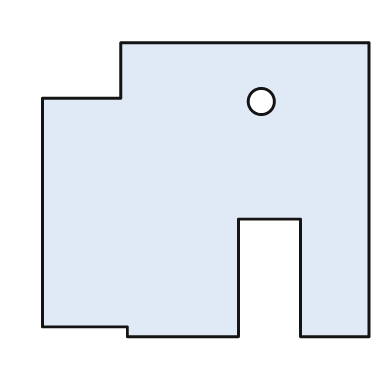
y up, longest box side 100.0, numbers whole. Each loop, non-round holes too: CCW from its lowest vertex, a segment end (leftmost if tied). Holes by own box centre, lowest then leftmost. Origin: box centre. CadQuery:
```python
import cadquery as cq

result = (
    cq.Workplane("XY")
    .moveTo(-24.0, -45.0)
    .lineTo(10.0, -45.0)
    .lineTo(10.0, -9.0)
    .lineTo(29.0, -9.0)
    .lineTo(29.0, -45.0)
    .lineTo(50.0, -45.0)
    .lineTo(50.0, 45.0)
    .lineTo(-26.0, 45.0)
    .lineTo(-26.0, 28.0)
    .lineTo(-50.0, 28.0)
    .lineTo(-50.0, -42.0)
    .lineTo(-24.0, -42.0)
    .close()
    .moveTo(17.0, 27.0)
    .circle(4.0)
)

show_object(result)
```